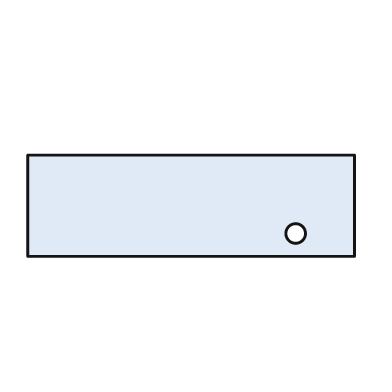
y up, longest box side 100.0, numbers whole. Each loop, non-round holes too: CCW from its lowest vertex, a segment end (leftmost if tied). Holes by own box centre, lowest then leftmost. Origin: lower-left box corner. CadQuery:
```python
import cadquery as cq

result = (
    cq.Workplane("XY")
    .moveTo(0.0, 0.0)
    .lineTo(100.0, 0.0)
    .lineTo(100.0, 31.0)
    .lineTo(0.0, 31.0)
    .close()
    .moveTo(82.0, 7.0)
    .circle(3.0)
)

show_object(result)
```